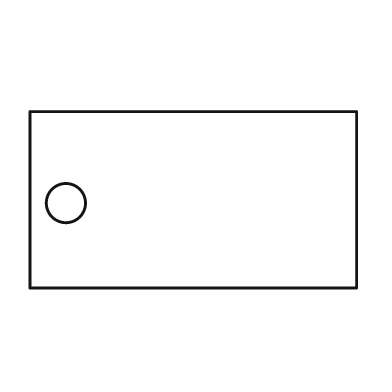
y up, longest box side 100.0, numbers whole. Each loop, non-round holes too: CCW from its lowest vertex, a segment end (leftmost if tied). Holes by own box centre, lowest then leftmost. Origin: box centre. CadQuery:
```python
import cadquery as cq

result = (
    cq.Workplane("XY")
    .moveTo(-50.0, -27.0)
    .lineTo(50.0, -27.0)
    .lineTo(50.0, 27.0)
    .lineTo(-50.0, 27.0)
    .close()
    .moveTo(-39.0, -1.0)
    .circle(6.0)
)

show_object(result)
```